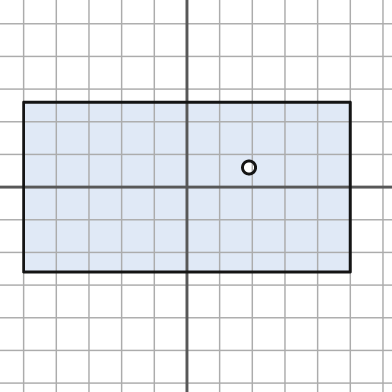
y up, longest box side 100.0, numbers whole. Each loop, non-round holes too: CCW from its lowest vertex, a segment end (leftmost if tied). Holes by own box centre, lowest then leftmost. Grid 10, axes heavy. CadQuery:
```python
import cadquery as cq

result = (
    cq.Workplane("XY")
    .moveTo(-50.0, -26.0)
    .lineTo(50.0, -26.0)
    .lineTo(50.0, 26.0)
    .lineTo(-50.0, 26.0)
    .close()
    .moveTo(19.0, 6.0)
    .circle(2.0)
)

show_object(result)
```